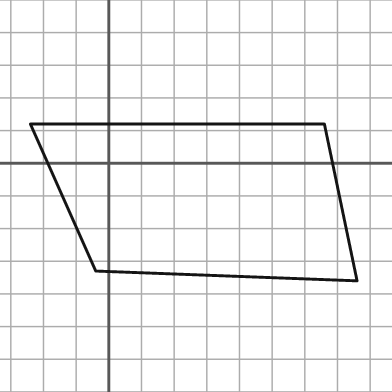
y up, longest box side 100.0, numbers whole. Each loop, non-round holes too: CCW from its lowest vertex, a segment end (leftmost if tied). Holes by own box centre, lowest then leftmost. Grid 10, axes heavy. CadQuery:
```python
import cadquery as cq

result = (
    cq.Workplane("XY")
    .moveTo(76.0, -36.0)
    .lineTo(66.0, 12.0)
    .lineTo(-24.0, 12.0)
    .lineTo(-4.0, -33.0)
    .close()
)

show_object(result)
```